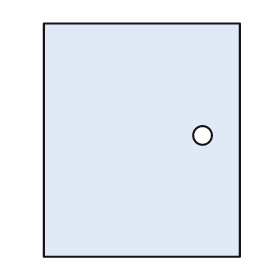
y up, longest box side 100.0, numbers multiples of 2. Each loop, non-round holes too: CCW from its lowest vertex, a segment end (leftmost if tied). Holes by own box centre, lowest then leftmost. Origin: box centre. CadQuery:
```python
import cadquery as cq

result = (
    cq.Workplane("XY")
    .moveTo(-42.0, -50.0)
    .lineTo(42.0, -50.0)
    .lineTo(42.0, 50.0)
    .lineTo(-42.0, 50.0)
    .close()
    .moveTo(26.0, 2.0)
    .circle(4.0)
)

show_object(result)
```